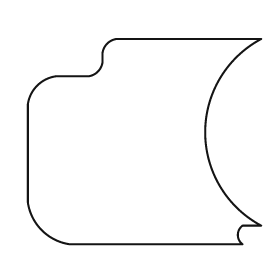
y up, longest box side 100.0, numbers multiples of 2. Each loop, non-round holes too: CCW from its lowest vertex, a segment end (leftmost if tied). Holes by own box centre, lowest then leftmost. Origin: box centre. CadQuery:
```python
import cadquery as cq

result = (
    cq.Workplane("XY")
    .moveTo(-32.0, -44.0)
    .lineTo(42.0, -44.0)
    .threePointArc((40.0, -40.0), (42.0, -36.0))
    .lineTo(50.0, -36.0)
    .threePointArc((26.0, 4.0), (50.0, 44.0))
    .lineTo(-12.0, 44.0)
    .threePointArc((-16.0, 42.0), (-18.0, 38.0))
    .lineTo(-18.0, 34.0)
    .threePointArc((-20.0, 30.0), (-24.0, 28.0))
    .lineTo(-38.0, 28.0)
    .threePointArc((-46.0, 24.0), (-50.0, 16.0))
    .lineTo(-50.0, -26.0)
    .threePointArc((-44.0, -38.0), (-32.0, -44.0))
    .close()
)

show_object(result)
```